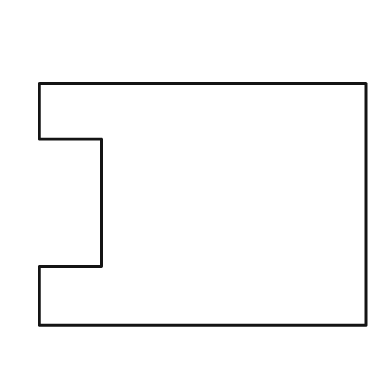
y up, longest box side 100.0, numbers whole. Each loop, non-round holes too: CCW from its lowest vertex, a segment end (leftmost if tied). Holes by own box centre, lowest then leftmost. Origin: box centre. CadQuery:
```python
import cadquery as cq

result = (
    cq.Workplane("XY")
    .moveTo(-50.0, -37.0)
    .lineTo(50.0, -37.0)
    .lineTo(50.0, 37.0)
    .lineTo(-50.0, 37.0)
    .lineTo(-50.0, 20.0)
    .lineTo(-31.0, 20.0)
    .lineTo(-31.0, -19.0)
    .lineTo(-50.0, -19.0)
    .close()
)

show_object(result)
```